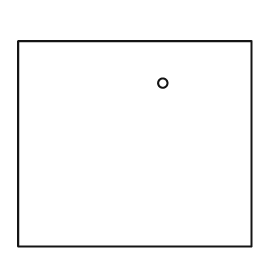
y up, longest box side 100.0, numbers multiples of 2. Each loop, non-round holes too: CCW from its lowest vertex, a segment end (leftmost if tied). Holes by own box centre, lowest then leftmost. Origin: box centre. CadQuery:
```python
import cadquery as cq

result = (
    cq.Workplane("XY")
    .moveTo(-50.0, -44.0)
    .lineTo(50.0, -44.0)
    .lineTo(50.0, 44.0)
    .lineTo(-50.0, 44.0)
    .close()
    .moveTo(12.0, 26.0)
    .circle(2.0)
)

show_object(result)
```